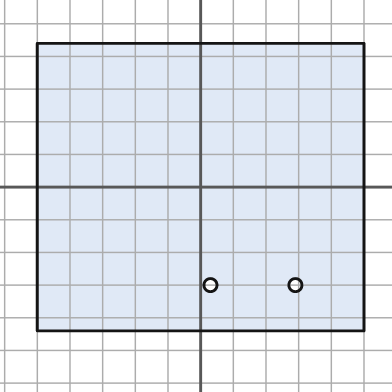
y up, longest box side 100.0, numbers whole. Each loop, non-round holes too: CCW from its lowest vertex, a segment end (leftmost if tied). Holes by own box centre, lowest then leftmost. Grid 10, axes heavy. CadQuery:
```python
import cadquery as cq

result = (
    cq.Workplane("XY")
    .moveTo(-50.0, -44.0)
    .lineTo(50.0, -44.0)
    .lineTo(50.0, 44.0)
    .lineTo(-50.0, 44.0)
    .close()
    .moveTo(3.0, -30.0)
    .circle(2.0)
    .moveTo(29.0, -30.0)
    .circle(2.0)
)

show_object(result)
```